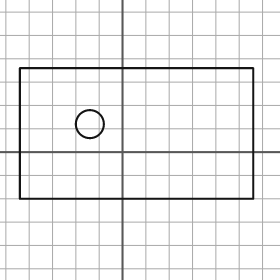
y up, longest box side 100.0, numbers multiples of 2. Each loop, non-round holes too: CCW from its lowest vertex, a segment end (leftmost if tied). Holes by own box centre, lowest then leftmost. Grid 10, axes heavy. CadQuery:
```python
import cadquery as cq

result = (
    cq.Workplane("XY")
    .moveTo(-44.0, -20.0)
    .lineTo(56.0, -20.0)
    .lineTo(56.0, 36.0)
    .lineTo(-44.0, 36.0)
    .close()
    .moveTo(-14.0, 12.0)
    .circle(6.0)
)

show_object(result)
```